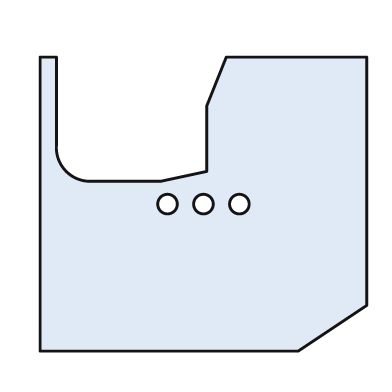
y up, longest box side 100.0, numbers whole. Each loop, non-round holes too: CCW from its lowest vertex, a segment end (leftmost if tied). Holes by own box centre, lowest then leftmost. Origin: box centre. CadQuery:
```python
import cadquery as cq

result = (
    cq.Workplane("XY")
    .moveTo(-50.0, -45.0)
    .lineTo(29.0, -45.0)
    .lineTo(50.0, -31.0)
    .lineTo(50.0, 45.0)
    .lineTo(7.0, 45.0)
    .lineTo(1.0, 30.0)
    .lineTo(1.0, 10.0)
    .lineTo(-13.0, 7.0)
    .lineTo(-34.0, 7.0)
    .threePointArc((-42.0, 10.0), (-45.0, 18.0))
    .lineTo(-45.0, 45.0)
    .lineTo(-50.0, 45.0)
    .close()
    .moveTo(-11.0, 0.0)
    .circle(3.0)
    .moveTo(0.0, 0.0)
    .circle(3.0)
    .moveTo(11.0, 0.0)
    .circle(3.0)
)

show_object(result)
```